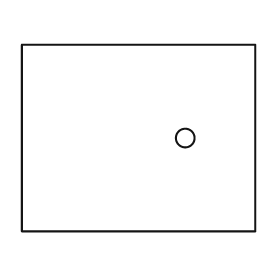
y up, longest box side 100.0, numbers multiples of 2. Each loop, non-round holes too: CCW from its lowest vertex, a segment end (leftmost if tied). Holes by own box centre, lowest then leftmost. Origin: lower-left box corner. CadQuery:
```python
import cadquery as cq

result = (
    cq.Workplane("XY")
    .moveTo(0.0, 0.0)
    .lineTo(100.0, 0.0)
    .lineTo(100.0, 80.0)
    .lineTo(0.0, 80.0)
    .close()
    .moveTo(70.0, 40.0)
    .circle(4.0)
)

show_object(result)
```